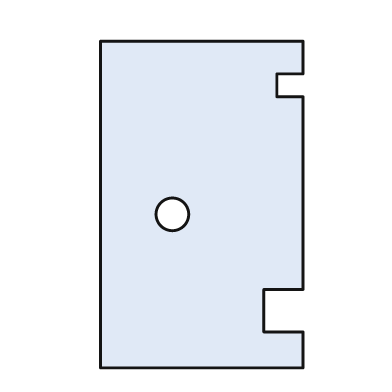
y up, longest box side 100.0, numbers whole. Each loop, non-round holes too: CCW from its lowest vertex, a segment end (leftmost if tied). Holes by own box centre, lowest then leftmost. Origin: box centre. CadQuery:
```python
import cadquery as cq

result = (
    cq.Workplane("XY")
    .moveTo(-31.0, -50.0)
    .lineTo(31.0, -50.0)
    .lineTo(31.0, -39.0)
    .lineTo(19.0, -39.0)
    .lineTo(19.0, -26.0)
    .lineTo(31.0, -26.0)
    .lineTo(31.0, 33.0)
    .lineTo(23.0, 33.0)
    .lineTo(23.0, 40.0)
    .lineTo(31.0, 40.0)
    .lineTo(31.0, 50.0)
    .lineTo(-31.0, 50.0)
    .close()
    .moveTo(-9.0, -3.0)
    .circle(5.0)
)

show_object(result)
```